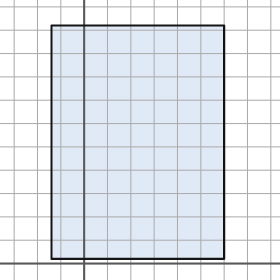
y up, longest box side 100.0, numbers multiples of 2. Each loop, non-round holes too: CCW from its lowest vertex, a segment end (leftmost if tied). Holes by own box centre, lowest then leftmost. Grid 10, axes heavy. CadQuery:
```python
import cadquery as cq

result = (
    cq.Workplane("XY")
    .moveTo(-14.0, 2.0)
    .lineTo(60.0, 2.0)
    .lineTo(60.0, 102.0)
    .lineTo(-14.0, 102.0)
    .close()
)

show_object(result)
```